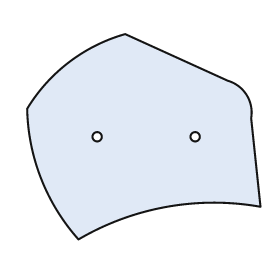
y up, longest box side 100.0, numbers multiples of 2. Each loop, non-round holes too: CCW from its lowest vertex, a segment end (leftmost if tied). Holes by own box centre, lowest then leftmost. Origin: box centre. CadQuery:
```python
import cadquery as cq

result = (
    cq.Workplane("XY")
    .moveTo(-28.0, -44.0)
    .threePointArc((10.0, -30.0), (50.0, -30.0))
    .lineTo(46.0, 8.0)
    .threePointArc((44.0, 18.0), (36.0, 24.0))
    .lineTo(-8.0, 44.0)
    .threePointArc((-32.0, 32.0), (-50.0, 12.0))
    .threePointArc((-44.0, -18.0), (-28.0, -44.0))
    .close()
    .moveTo(-20.0, 0.0)
    .circle(2.0)
    .moveTo(22.0, 0.0)
    .circle(2.0)
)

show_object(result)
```